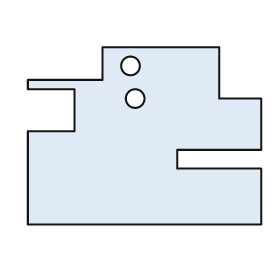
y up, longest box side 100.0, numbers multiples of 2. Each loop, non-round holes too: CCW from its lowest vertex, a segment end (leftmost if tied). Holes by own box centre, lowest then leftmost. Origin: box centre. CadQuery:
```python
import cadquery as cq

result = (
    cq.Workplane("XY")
    .moveTo(-50.0, -38.0)
    .lineTo(50.0, -38.0)
    .lineTo(50.0, -14.0)
    .lineTo(14.0, -14.0)
    .lineTo(14.0, -6.0)
    .lineTo(50.0, -6.0)
    .lineTo(50.0, 16.0)
    .lineTo(32.0, 16.0)
    .lineTo(32.0, 38.0)
    .lineTo(-18.0, 38.0)
    .lineTo(-18.0, 24.0)
    .lineTo(-50.0, 24.0)
    .lineTo(-50.0, 20.0)
    .lineTo(-30.0, 20.0)
    .lineTo(-30.0, 2.0)
    .lineTo(-50.0, 2.0)
    .close()
    .moveTo(-4.0, 16.0)
    .circle(4.0)
    .moveTo(-6.0, 30.0)
    .circle(4.0)
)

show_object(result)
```